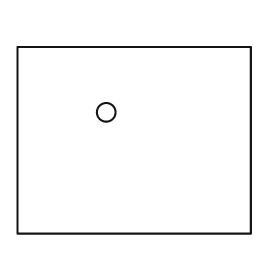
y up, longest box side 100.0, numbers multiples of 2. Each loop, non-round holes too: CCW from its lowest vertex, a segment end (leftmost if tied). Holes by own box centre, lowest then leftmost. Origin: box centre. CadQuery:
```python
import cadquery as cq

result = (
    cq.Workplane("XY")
    .moveTo(-50.0, -40.0)
    .lineTo(50.0, -40.0)
    .lineTo(50.0, 40.0)
    .lineTo(-50.0, 40.0)
    .close()
    .moveTo(-12.0, 12.0)
    .circle(4.0)
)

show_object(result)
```